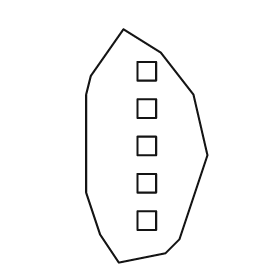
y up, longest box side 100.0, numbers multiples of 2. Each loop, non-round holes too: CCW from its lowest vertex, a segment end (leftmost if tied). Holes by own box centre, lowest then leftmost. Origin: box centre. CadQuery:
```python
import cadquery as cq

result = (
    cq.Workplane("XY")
    .moveTo(-12.0, -50.0)
    .lineTo(8.0, -46.0)
    .lineTo(14.0, -40.0)
    .lineTo(26.0, -4.0)
    .lineTo(20.0, 22.0)
    .lineTo(6.0, 40.0)
    .lineTo(-10.0, 50.0)
    .lineTo(-24.0, 30.0)
    .lineTo(-26.0, 22.0)
    .lineTo(-26.0, -20.0)
    .lineTo(-20.0, -38.0)
    .close()
    .moveTo(-4.0, -36.0)
    .lineTo(4.0, -36.0)
    .lineTo(4.0, -28.0)
    .lineTo(-4.0, -28.0)
    .close()
    .moveTo(-4.0, -20.0)
    .lineTo(4.0, -20.0)
    .lineTo(4.0, -12.0)
    .lineTo(-4.0, -12.0)
    .close()
    .moveTo(-4.0, -4.0)
    .lineTo(4.0, -4.0)
    .lineTo(4.0, 4.0)
    .lineTo(-4.0, 4.0)
    .close()
    .moveTo(-4.0, 12.0)
    .lineTo(4.0, 12.0)
    .lineTo(4.0, 20.0)
    .lineTo(-4.0, 20.0)
    .close()
    .moveTo(-4.0, 28.0)
    .lineTo(4.0, 28.0)
    .lineTo(4.0, 36.0)
    .lineTo(-4.0, 36.0)
    .close()
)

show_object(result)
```